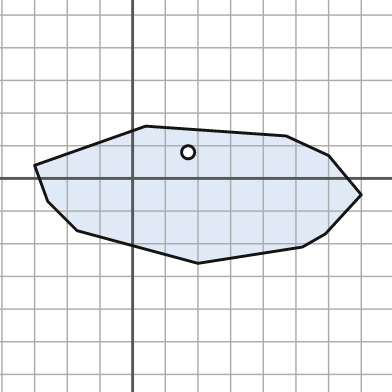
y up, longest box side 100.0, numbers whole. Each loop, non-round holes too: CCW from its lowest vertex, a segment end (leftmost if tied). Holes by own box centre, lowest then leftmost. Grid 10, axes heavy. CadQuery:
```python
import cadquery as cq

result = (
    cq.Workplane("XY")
    .moveTo(20.0, -26.0)
    .lineTo(52.0, -21.0)
    .lineTo(59.0, -17.0)
    .lineTo(70.0, -5.0)
    .lineTo(60.0, 7.0)
    .lineTo(47.0, 13.0)
    .lineTo(4.0, 16.0)
    .lineTo(-30.0, 4.0)
    .lineTo(-26.0, -7.0)
    .lineTo(-17.0, -16.0)
    .close()
    .moveTo(17.0, 8.0)
    .circle(2.0)
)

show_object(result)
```